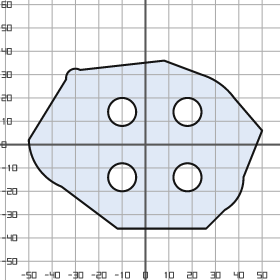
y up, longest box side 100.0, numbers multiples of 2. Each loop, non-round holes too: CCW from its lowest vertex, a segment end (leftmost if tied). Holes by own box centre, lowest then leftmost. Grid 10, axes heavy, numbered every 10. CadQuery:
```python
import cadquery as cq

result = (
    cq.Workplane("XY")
    .moveTo(-12.0, -36.0)
    .lineTo(26.0, -36.0)
    .lineTo(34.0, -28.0)
    .threePointArc((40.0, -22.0), (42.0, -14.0))
    .lineTo(50.0, 6.0)
    .lineTo(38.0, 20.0)
    .threePointArc((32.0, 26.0), (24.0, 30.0))
    .lineTo(8.0, 36.0)
    .lineTo(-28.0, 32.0)
    .threePointArc((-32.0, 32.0), (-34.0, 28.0))
    .lineTo(-50.0, 2.0)
    .threePointArc((-46.0, -10.0), (-36.0, -18.0))
    .close()
    .moveTo(-10.0, -14.0)
    .circle(6.0)
    .moveTo(18.0, -14.0)
    .circle(6.0)
    .moveTo(-10.0, 14.0)
    .circle(6.0)
    .moveTo(18.0, 14.0)
    .circle(6.0)
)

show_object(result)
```